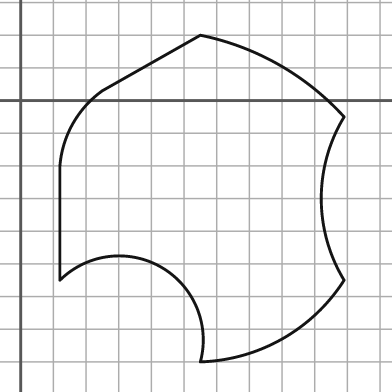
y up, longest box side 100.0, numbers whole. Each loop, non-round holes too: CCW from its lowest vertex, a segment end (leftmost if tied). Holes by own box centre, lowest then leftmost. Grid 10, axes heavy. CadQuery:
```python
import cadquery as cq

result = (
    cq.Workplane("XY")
    .moveTo(55.0, -80.0)
    .threePointArc((80.0, -73.0), (99.0, -55.0))
    .threePointArc((92.0, -30.0), (99.0, -5.0))
    .threePointArc((79.0, 11.0), (55.0, 20.0))
    .lineTo(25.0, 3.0)
    .threePointArc((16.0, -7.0), (12.0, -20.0))
    .lineTo(12.0, -55.0)
    .threePointArc((43.0, -51.0), (55.0, -80.0))
    .close()
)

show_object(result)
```